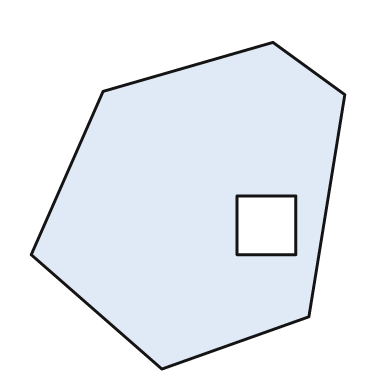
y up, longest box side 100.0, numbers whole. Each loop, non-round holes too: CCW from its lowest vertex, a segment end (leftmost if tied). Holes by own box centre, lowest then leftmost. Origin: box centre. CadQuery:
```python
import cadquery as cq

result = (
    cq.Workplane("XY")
    .moveTo(-8.0, -50.0)
    .lineTo(37.0, -34.0)
    .lineTo(48.0, 34.0)
    .lineTo(26.0, 50.0)
    .lineTo(-26.0, 35.0)
    .lineTo(-48.0, -15.0)
    .close()
    .moveTo(15.0, -15.0)
    .lineTo(33.0, -15.0)
    .lineTo(33.0, 3.0)
    .lineTo(15.0, 3.0)
    .close()
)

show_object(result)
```